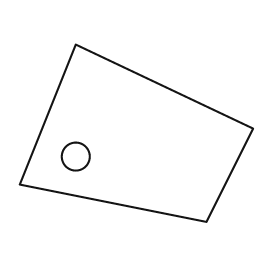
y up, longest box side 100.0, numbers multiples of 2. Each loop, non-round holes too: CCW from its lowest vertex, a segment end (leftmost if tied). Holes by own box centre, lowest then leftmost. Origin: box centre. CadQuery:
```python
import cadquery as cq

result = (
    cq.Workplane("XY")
    .moveTo(30.0, -38.0)
    .lineTo(50.0, 2.0)
    .lineTo(-26.0, 38.0)
    .lineTo(-50.0, -22.0)
    .close()
    .moveTo(-26.0, -10.0)
    .circle(6.0)
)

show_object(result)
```